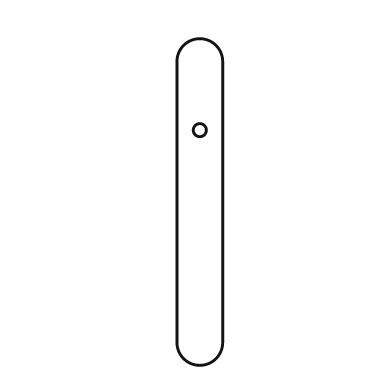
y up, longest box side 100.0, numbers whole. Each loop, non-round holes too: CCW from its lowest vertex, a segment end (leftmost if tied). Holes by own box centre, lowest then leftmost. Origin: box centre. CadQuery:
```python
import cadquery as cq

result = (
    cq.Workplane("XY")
    .moveTo(-7.0, -43.0)
    .threePointArc((0.0, -50.0), (7.0, -43.0))
    .lineTo(7.0, 43.0)
    .threePointArc((0.0, 50.0), (-7.0, 43.0))
    .close()
    .moveTo(0.0, 22.0)
    .circle(2.0)
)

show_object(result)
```